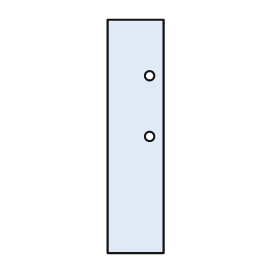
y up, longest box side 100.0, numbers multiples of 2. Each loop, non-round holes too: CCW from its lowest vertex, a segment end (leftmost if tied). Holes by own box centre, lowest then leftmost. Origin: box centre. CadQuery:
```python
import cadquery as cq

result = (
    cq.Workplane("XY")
    .moveTo(-12.0, -50.0)
    .lineTo(12.0, -50.0)
    .lineTo(12.0, 50.0)
    .lineTo(-12.0, 50.0)
    .close()
    .moveTo(6.0, 0.0)
    .circle(2.0)
    .moveTo(6.0, 26.0)
    .circle(2.0)
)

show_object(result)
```